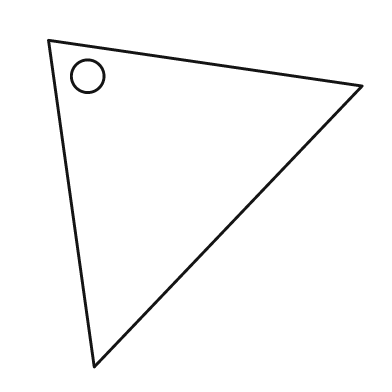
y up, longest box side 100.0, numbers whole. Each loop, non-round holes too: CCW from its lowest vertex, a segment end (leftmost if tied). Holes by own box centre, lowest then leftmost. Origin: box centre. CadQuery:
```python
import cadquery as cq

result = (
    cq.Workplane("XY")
    .moveTo(-34.0, -50.0)
    .lineTo(48.0, 36.0)
    .lineTo(-48.0, 50.0)
    .close()
    .moveTo(-36.0, 39.0)
    .circle(5.0)
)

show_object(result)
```